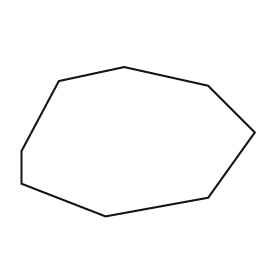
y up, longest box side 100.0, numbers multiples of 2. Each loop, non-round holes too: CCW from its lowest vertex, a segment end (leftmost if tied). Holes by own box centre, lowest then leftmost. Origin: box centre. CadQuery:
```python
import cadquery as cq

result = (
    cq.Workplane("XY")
    .moveTo(-14.0, -32.0)
    .lineTo(30.0, -24.0)
    .lineTo(50.0, 4.0)
    .lineTo(30.0, 24.0)
    .lineTo(-6.0, 32.0)
    .lineTo(-34.0, 26.0)
    .lineTo(-50.0, -4.0)
    .lineTo(-50.0, -18.0)
    .close()
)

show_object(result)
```